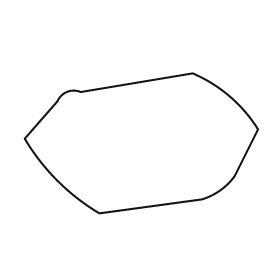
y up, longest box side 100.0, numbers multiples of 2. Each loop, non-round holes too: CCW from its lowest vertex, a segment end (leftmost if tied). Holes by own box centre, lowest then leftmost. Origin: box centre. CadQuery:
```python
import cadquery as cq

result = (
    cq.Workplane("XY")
    .moveTo(-18.0, -30.0)
    .lineTo(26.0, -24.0)
    .threePointArc((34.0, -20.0), (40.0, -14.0))
    .lineTo(50.0, 6.0)
    .threePointArc((38.0, 20.0), (22.0, 30.0))
    .lineTo(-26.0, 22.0)
    .threePointArc((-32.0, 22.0), (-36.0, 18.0))
    .lineTo(-50.0, 2.0)
    .threePointArc((-36.0, -16.0), (-18.0, -30.0))
    .close()
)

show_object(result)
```